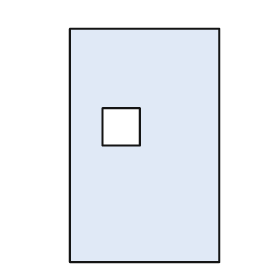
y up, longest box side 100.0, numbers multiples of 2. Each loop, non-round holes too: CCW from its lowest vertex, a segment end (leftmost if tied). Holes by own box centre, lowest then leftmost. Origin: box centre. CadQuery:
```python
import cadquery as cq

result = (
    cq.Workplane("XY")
    .moveTo(-32.0, -50.0)
    .lineTo(32.0, -50.0)
    .lineTo(32.0, 50.0)
    .lineTo(-32.0, 50.0)
    .close()
    .moveTo(-18.0, 0.0)
    .lineTo(-2.0, 0.0)
    .lineTo(-2.0, 16.0)
    .lineTo(-18.0, 16.0)
    .close()
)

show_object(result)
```